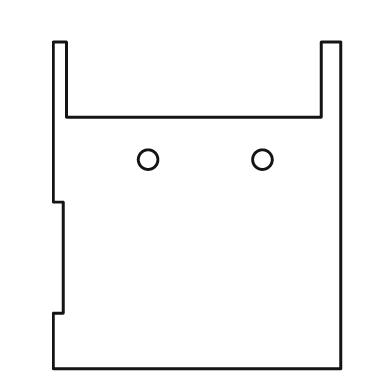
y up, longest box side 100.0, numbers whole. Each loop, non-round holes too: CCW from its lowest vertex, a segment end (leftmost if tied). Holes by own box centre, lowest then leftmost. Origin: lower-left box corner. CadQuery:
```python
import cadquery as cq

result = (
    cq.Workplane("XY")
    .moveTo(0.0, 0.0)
    .lineTo(88.0, 0.0)
    .lineTo(88.0, 100.0)
    .lineTo(82.0, 100.0)
    .lineTo(82.0, 77.0)
    .lineTo(4.0, 77.0)
    .lineTo(4.0, 100.0)
    .lineTo(0.0, 100.0)
    .lineTo(0.0, 51.0)
    .lineTo(3.0, 51.0)
    .lineTo(3.0, 17.0)
    .lineTo(0.0, 17.0)
    .close()
    .moveTo(29.0, 64.0)
    .circle(3.0)
    .moveTo(64.0, 64.0)
    .circle(3.0)
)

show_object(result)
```